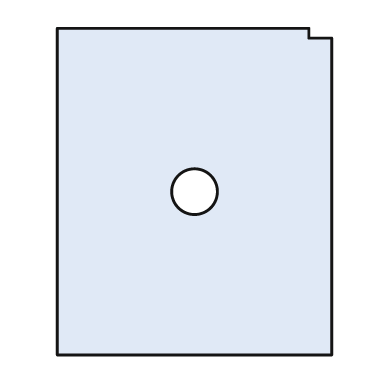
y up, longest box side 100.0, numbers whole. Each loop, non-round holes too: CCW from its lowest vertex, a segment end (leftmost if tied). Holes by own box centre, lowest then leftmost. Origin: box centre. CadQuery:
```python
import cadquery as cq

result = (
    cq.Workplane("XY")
    .moveTo(-42.0, -50.0)
    .lineTo(42.0, -50.0)
    .lineTo(42.0, 47.0)
    .lineTo(35.0, 47.0)
    .lineTo(35.0, 50.0)
    .lineTo(-42.0, 50.0)
    .close()
    .moveTo(0.0, 0.0)
    .circle(7.0)
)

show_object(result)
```